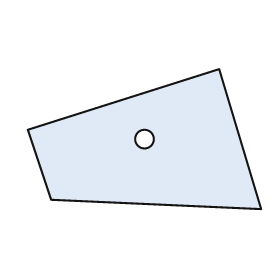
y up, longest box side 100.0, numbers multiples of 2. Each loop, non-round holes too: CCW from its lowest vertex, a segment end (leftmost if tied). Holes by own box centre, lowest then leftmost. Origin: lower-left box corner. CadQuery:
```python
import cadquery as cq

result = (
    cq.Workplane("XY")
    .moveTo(100.0, 0.0)
    .lineTo(82.0, 60.0)
    .lineTo(0.0, 34.0)
    .lineTo(10.0, 4.0)
    .close()
    .moveTo(50.0, 30.0)
    .circle(4.0)
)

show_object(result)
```